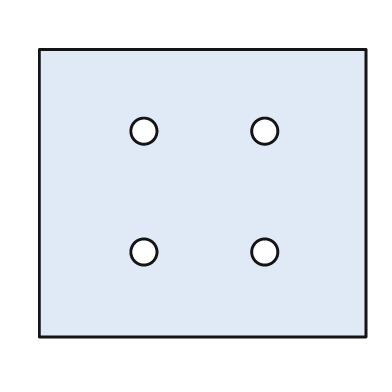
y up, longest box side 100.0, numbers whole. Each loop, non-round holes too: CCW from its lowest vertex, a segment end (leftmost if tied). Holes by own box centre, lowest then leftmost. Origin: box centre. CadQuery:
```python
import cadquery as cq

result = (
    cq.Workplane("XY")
    .moveTo(-50.0, -44.0)
    .lineTo(50.0, -44.0)
    .lineTo(50.0, 44.0)
    .lineTo(-50.0, 44.0)
    .close()
    .moveTo(-18.0, -18.0)
    .circle(4.0)
    .moveTo(19.0, -18.0)
    .circle(4.0)
    .moveTo(-18.0, 19.0)
    .circle(4.0)
    .moveTo(19.0, 19.0)
    .circle(4.0)
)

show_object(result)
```